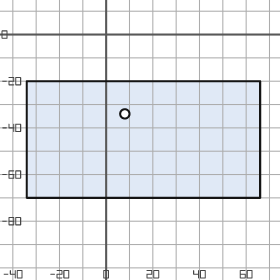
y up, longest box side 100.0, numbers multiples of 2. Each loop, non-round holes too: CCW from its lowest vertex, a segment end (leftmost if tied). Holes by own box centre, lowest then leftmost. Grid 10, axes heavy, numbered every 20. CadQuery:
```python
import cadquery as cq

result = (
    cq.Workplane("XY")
    .moveTo(-34.0, -70.0)
    .lineTo(66.0, -70.0)
    .lineTo(66.0, -20.0)
    .lineTo(-34.0, -20.0)
    .close()
    .moveTo(8.0, -34.0)
    .circle(2.0)
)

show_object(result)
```